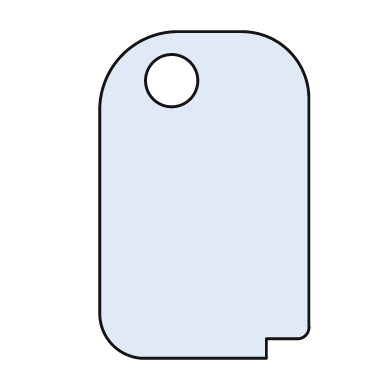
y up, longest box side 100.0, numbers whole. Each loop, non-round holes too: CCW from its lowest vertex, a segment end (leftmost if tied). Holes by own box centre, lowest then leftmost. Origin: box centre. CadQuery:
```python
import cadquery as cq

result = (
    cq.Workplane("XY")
    .moveTo(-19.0, -50.0)
    .lineTo(19.0, -50.0)
    .lineTo(19.0, -44.0)
    .lineTo(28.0, -44.0)
    .threePointArc((31.0, -43.0), (32.0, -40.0))
    .lineTo(32.0, 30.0)
    .threePointArc((26.0, 44.0), (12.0, 50.0))
    .lineTo(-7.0, 50.0)
    .threePointArc((-25.0, 43.0), (-32.0, 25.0))
    .lineTo(-32.0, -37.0)
    .threePointArc((-28.0, -46.0), (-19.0, -50.0))
    .close()
    .moveTo(-10.0, 35.0)
    .circle(8.0)
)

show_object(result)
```